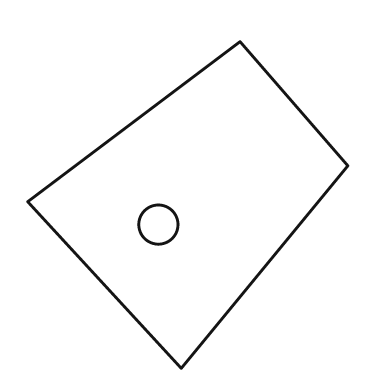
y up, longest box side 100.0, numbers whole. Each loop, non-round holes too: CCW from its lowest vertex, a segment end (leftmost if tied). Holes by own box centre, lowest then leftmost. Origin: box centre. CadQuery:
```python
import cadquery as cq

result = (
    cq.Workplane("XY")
    .moveTo(-2.0, -50.0)
    .lineTo(49.0, 12.0)
    .lineTo(16.0, 50.0)
    .lineTo(-49.0, 1.0)
    .close()
    .moveTo(-9.0, -6.0)
    .circle(6.0)
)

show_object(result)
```